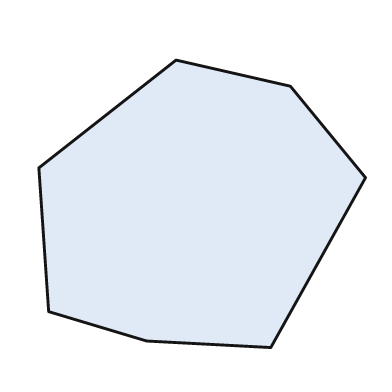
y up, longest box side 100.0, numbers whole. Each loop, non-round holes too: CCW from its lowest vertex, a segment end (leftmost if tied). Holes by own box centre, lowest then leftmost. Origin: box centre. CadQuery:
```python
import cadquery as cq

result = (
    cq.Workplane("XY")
    .moveTo(21.0, -44.0)
    .lineTo(50.0, 8.0)
    .lineTo(27.0, 36.0)
    .lineTo(-8.0, 44.0)
    .lineTo(-50.0, 11.0)
    .lineTo(-47.0, -33.0)
    .lineTo(-17.0, -42.0)
    .close()
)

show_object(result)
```